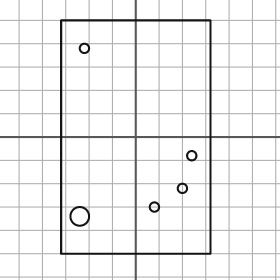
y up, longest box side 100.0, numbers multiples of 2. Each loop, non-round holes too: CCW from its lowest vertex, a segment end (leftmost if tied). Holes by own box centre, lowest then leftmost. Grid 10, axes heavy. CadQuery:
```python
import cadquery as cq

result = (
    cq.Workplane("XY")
    .moveTo(-32.0, -50.0)
    .lineTo(32.0, -50.0)
    .lineTo(32.0, 50.0)
    .lineTo(-32.0, 50.0)
    .close()
    .moveTo(-24.0, -34.0)
    .circle(4.0)
    .moveTo(8.0, -30.0)
    .circle(2.0)
    .moveTo(20.0, -22.0)
    .circle(2.0)
    .moveTo(24.0, -8.0)
    .circle(2.0)
    .moveTo(-22.0, 38.0)
    .circle(2.0)
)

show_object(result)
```